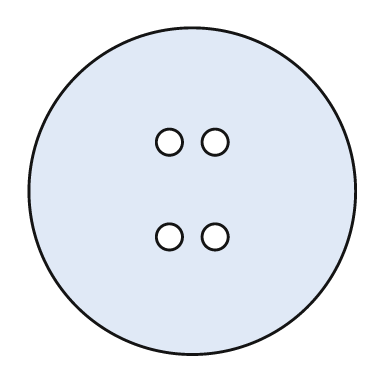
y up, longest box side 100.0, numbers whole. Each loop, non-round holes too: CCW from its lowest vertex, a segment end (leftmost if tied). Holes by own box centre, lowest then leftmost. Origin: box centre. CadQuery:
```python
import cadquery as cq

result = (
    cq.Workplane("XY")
    .moveTo(0.0, 0.0)
    .circle(50.0)
    .moveTo(-7.0, -14.0)
    .circle(4.0)
    .moveTo(7.0, -14.0)
    .circle(4.0)
    .moveTo(-7.0, 15.0)
    .circle(4.0)
    .moveTo(7.0, 15.0)
    .circle(4.0)
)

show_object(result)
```